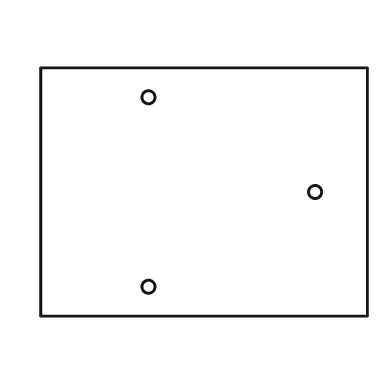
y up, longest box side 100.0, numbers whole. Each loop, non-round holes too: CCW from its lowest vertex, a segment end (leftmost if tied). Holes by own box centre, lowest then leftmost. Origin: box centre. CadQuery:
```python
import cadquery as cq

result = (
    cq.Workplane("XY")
    .moveTo(-50.0, -38.0)
    .lineTo(50.0, -38.0)
    .lineTo(50.0, 38.0)
    .lineTo(-50.0, 38.0)
    .close()
    .moveTo(-17.0, -29.0)
    .circle(2.0)
    .moveTo(34.0, 0.0)
    .circle(2.0)
    .moveTo(-17.0, 29.0)
    .circle(2.0)
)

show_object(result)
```